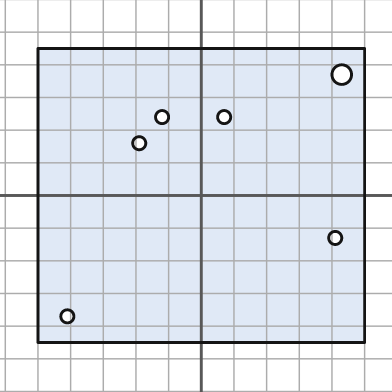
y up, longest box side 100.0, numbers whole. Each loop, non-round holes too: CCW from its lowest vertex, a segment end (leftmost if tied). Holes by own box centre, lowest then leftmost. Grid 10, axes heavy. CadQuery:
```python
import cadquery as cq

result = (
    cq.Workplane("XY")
    .moveTo(-50.0, -45.0)
    .lineTo(50.0, -45.0)
    .lineTo(50.0, 45.0)
    .lineTo(-50.0, 45.0)
    .close()
    .moveTo(-41.0, -37.0)
    .circle(2.0)
    .moveTo(41.0, -13.0)
    .circle(2.0)
    .moveTo(-19.0, 16.0)
    .circle(2.0)
    .moveTo(-12.0, 24.0)
    .circle(2.0)
    .moveTo(7.0, 24.0)
    .circle(2.0)
    .moveTo(43.0, 37.0)
    .circle(3.0)
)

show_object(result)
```